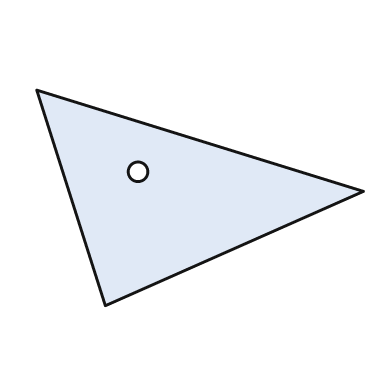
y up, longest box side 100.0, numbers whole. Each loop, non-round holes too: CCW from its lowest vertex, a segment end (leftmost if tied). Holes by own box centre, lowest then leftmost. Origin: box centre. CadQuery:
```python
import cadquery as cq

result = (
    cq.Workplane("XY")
    .moveTo(-29.0, -33.0)
    .lineTo(50.0, 2.0)
    .lineTo(-50.0, 33.0)
    .close()
    .moveTo(-19.0, 8.0)
    .circle(3.0)
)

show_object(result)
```